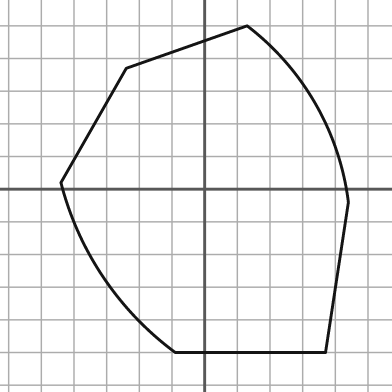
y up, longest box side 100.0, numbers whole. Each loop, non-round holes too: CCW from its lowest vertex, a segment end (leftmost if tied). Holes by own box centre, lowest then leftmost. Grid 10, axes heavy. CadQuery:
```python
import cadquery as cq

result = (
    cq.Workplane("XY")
    .moveTo(-9.0, -50.0)
    .lineTo(37.0, -50.0)
    .lineTo(44.0, -4.0)
    .threePointArc((34.0, 26.0), (13.0, 50.0))
    .lineTo(-24.0, 37.0)
    .lineTo(-44.0, 2.0)
    .threePointArc((-31.0, -27.0), (-9.0, -50.0))
    .close()
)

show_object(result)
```